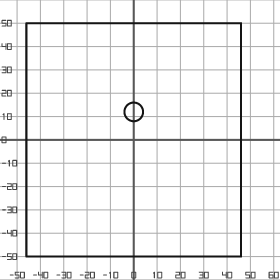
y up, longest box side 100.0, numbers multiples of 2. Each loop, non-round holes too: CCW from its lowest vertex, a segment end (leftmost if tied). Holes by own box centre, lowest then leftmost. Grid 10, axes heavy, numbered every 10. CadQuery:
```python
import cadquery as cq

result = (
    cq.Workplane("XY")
    .moveTo(-46.0, -50.0)
    .lineTo(46.0, -50.0)
    .lineTo(46.0, 50.0)
    .lineTo(-46.0, 50.0)
    .close()
    .moveTo(0.0, 12.0)
    .circle(4.0)
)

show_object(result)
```